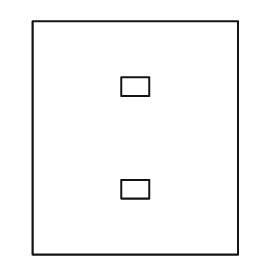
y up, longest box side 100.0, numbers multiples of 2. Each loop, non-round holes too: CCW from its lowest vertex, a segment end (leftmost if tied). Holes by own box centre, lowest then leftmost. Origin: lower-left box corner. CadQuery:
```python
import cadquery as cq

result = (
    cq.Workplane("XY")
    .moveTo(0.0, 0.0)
    .lineTo(88.0, 0.0)
    .lineTo(88.0, 100.0)
    .lineTo(0.0, 100.0)
    .close()
    .moveTo(38.0, 24.0)
    .lineTo(50.0, 24.0)
    .lineTo(50.0, 32.0)
    .lineTo(38.0, 32.0)
    .close()
    .moveTo(38.0, 68.0)
    .lineTo(50.0, 68.0)
    .lineTo(50.0, 76.0)
    .lineTo(38.0, 76.0)
    .close()
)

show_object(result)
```